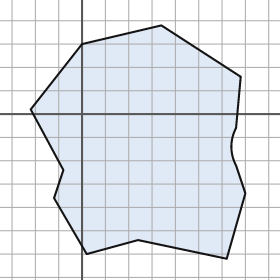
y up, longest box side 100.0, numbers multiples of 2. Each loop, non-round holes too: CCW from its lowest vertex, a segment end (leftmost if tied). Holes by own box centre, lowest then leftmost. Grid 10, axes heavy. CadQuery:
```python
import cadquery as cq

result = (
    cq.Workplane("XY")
    .moveTo(62.0, -62.0)
    .lineTo(70.0, -34.0)
    .lineTo(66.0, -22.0)
    .threePointArc((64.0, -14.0), (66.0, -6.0))
    .lineTo(68.0, 16.0)
    .lineTo(34.0, 38.0)
    .lineTo(0.0, 30.0)
    .lineTo(-22.0, 2.0)
    .lineTo(-8.0, -24.0)
    .lineTo(-12.0, -36.0)
    .lineTo(2.0, -60.0)
    .lineTo(24.0, -54.0)
    .close()
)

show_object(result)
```